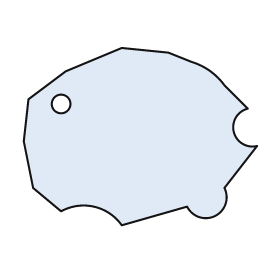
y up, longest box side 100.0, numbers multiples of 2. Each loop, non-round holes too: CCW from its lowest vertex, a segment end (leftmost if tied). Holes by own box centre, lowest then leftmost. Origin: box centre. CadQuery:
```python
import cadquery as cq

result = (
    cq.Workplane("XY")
    .moveTo(-8.0, -38.0)
    .lineTo(20.0, -30.0)
    .threePointArc((32.0, -34.0), (36.0, -22.0))
    .lineTo(50.0, -4.0)
    .threePointArc((40.0, 2.0), (46.0, 12.0))
    .lineTo(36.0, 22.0)
    .threePointArc((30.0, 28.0), (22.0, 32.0))
    .lineTo(12.0, 36.0)
    .lineTo(-8.0, 38.0)
    .lineTo(-32.0, 28.0)
    .lineTo(-48.0, 16.0)
    .lineTo(-50.0, -2.0)
    .lineTo(-46.0, -22.0)
    .lineTo(-34.0, -32.0)
    .threePointArc((-20.0, -30.0), (-8.0, -38.0))
    .close()
    .moveTo(-34.0, 14.0)
    .circle(4.0)
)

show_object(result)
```